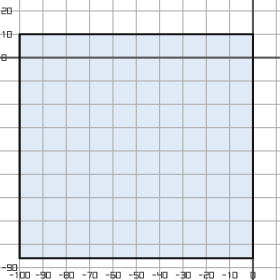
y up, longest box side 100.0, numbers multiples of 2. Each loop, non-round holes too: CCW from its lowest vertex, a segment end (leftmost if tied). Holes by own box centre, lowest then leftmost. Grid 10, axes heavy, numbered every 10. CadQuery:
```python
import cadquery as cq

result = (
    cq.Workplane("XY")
    .moveTo(-100.0, -86.0)
    .lineTo(0.0, -86.0)
    .lineTo(0.0, 10.0)
    .lineTo(-100.0, 10.0)
    .close()
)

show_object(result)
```